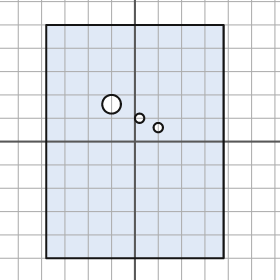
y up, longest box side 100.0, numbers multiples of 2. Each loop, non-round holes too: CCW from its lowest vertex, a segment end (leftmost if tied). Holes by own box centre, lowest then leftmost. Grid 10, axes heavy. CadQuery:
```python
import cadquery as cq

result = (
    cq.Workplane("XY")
    .moveTo(-38.0, -50.0)
    .lineTo(38.0, -50.0)
    .lineTo(38.0, 50.0)
    .lineTo(-38.0, 50.0)
    .close()
    .moveTo(10.0, 6.0)
    .circle(2.0)
    .moveTo(2.0, 10.0)
    .circle(2.0)
    .moveTo(-10.0, 16.0)
    .circle(4.0)
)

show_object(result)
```